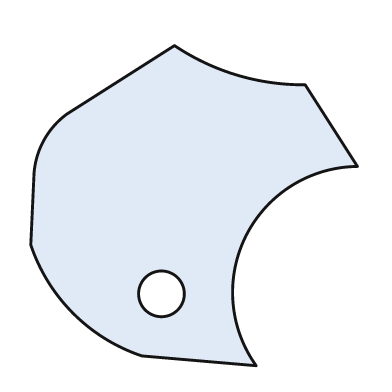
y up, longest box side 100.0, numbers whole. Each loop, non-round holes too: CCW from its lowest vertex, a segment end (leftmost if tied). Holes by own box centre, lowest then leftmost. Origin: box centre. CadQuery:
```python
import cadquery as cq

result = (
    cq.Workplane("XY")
    .moveTo(19.0, -49.0)
    .threePointArc((16.0, -9.0), (50.0, 12.0))
    .lineTo(34.0, 37.0)
    .threePointArc((13.0, 40.0), (-6.0, 49.0))
    .lineTo(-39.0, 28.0)
    .threePointArc((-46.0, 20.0), (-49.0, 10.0))
    .lineTo(-50.0, -12.0)
    .threePointArc((-37.0, -33.0), (-16.0, -46.0))
    .close()
    .moveTo(-10.0, -27.0)
    .circle(7.0)
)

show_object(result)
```